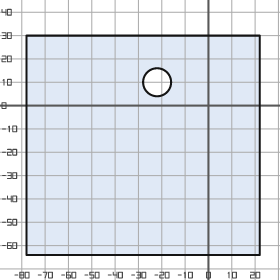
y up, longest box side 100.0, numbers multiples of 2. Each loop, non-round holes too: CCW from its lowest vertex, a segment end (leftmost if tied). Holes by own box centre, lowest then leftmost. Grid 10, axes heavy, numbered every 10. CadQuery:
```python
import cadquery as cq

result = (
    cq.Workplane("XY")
    .moveTo(-78.0, -64.0)
    .lineTo(22.0, -64.0)
    .lineTo(22.0, 30.0)
    .lineTo(-78.0, 30.0)
    .close()
    .moveTo(-22.0, 10.0)
    .circle(6.0)
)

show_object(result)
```